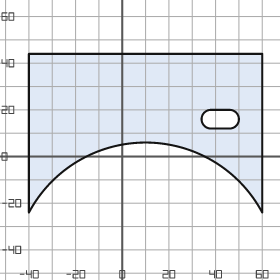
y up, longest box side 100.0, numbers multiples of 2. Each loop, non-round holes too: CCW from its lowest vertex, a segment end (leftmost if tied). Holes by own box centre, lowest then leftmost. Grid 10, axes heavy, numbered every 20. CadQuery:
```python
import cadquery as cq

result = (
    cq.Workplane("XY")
    .moveTo(-40.0, -24.0)
    .threePointArc((10.0, 6.0), (60.0, -24.0))
    .lineTo(60.0, 44.0)
    .lineTo(-40.0, 44.0)
    .close()
    .moveTo(38.0, 12.0)
    .lineTo(46.0, 12.0)
    .threePointArc((50.0, 16.0), (46.0, 20.0))
    .lineTo(38.0, 20.0)
    .threePointArc((34.0, 16.0), (38.0, 12.0))
    .close()
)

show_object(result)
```